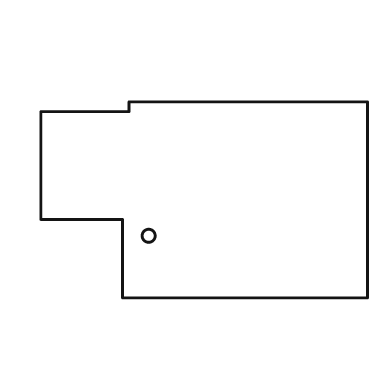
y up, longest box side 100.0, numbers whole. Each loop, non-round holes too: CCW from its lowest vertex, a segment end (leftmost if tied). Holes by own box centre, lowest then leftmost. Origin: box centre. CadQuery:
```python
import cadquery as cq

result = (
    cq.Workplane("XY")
    .moveTo(-25.0, -30.0)
    .lineTo(50.0, -30.0)
    .lineTo(50.0, 30.0)
    .lineTo(-23.0, 30.0)
    .lineTo(-23.0, 27.0)
    .lineTo(-50.0, 27.0)
    .lineTo(-50.0, -6.0)
    .lineTo(-25.0, -6.0)
    .close()
    .moveTo(-17.0, -11.0)
    .circle(2.0)
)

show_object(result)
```